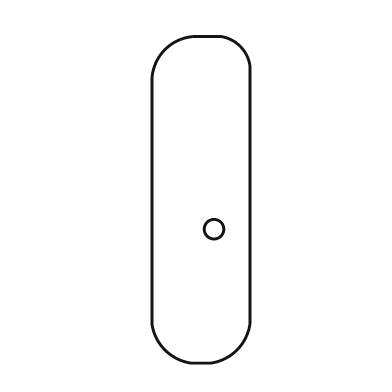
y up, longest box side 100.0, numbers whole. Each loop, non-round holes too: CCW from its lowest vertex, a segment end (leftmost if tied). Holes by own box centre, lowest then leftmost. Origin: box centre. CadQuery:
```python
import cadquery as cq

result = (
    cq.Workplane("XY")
    .moveTo(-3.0, -50.0)
    .lineTo(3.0, -50.0)
    .threePointArc((11.0, -46.0), (15.0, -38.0))
    .lineTo(15.0, 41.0)
    .threePointArc((12.0, 47.0), (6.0, 50.0))
    .lineTo(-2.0, 50.0)
    .threePointArc((-11.0, 46.0), (-15.0, 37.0))
    .lineTo(-15.0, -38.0)
    .threePointArc((-11.0, -46.0), (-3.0, -50.0))
    .close()
    .moveTo(4.0, -9.0)
    .circle(3.0)
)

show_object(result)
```